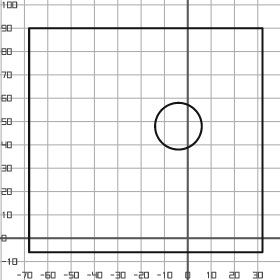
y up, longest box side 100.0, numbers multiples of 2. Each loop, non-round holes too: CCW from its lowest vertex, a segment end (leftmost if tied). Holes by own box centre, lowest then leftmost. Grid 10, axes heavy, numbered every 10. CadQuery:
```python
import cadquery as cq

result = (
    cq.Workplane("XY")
    .moveTo(-68.0, -6.0)
    .lineTo(32.0, -6.0)
    .lineTo(32.0, 90.0)
    .lineTo(-68.0, 90.0)
    .close()
    .moveTo(-4.0, 48.0)
    .circle(10.0)
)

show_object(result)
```